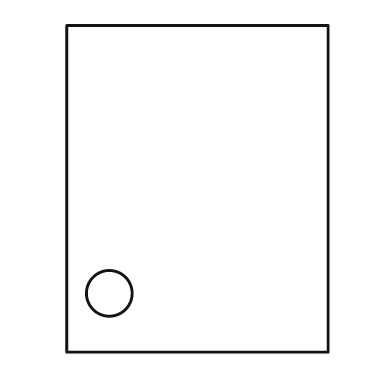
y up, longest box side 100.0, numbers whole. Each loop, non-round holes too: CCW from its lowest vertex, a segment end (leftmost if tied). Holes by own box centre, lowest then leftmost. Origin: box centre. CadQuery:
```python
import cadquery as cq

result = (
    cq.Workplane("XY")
    .moveTo(-40.0, -50.0)
    .lineTo(40.0, -50.0)
    .lineTo(40.0, 50.0)
    .lineTo(-40.0, 50.0)
    .close()
    .moveTo(-27.0, -32.0)
    .circle(7.0)
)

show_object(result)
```